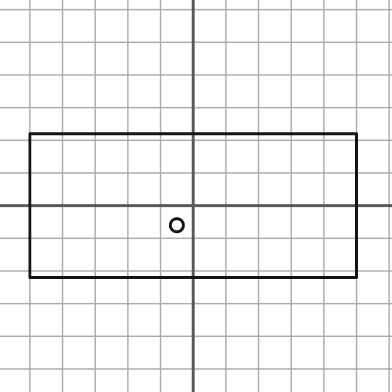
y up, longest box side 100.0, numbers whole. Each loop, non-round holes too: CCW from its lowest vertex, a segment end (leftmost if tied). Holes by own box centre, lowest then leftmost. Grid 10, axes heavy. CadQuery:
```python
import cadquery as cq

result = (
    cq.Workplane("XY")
    .moveTo(-50.0, -22.0)
    .lineTo(50.0, -22.0)
    .lineTo(50.0, 22.0)
    .lineTo(-50.0, 22.0)
    .close()
    .moveTo(-5.0, -6.0)
    .circle(2.0)
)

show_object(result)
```